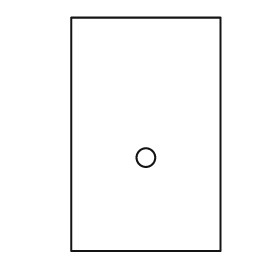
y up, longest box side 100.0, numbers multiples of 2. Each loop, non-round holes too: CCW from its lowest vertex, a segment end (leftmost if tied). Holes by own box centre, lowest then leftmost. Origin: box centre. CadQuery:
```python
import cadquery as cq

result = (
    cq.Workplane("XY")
    .moveTo(-32.0, -50.0)
    .lineTo(32.0, -50.0)
    .lineTo(32.0, 50.0)
    .lineTo(-32.0, 50.0)
    .close()
    .moveTo(0.0, -10.0)
    .circle(4.0)
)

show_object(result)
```